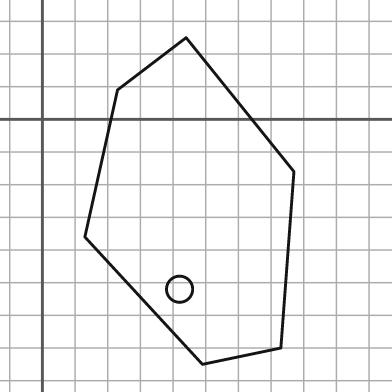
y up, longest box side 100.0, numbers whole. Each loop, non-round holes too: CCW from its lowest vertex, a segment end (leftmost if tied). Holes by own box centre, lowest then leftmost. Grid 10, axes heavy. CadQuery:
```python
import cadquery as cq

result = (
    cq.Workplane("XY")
    .moveTo(49.0, -75.0)
    .lineTo(73.0, -70.0)
    .lineTo(77.0, -16.0)
    .lineTo(44.0, 25.0)
    .lineTo(23.0, 9.0)
    .lineTo(13.0, -36.0)
    .close()
    .moveTo(42.0, -52.0)
    .circle(4.0)
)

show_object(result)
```